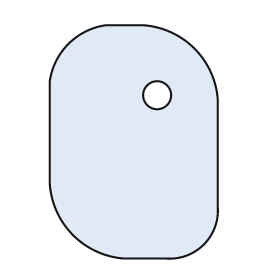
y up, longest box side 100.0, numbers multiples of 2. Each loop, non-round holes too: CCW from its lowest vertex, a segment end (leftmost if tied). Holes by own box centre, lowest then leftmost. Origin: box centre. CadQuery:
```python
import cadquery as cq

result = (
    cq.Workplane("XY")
    .moveTo(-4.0, -50.0)
    .lineTo(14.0, -50.0)
    .threePointArc((30.0, -44.0), (36.0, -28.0))
    .lineTo(36.0, 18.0)
    .threePointArc((26.0, 40.0), (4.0, 50.0))
    .lineTo(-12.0, 50.0)
    .threePointArc((-28.0, 42.0), (-36.0, 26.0))
    .lineTo(-36.0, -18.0)
    .threePointArc((-26.0, -40.0), (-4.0, -50.0))
    .close()
    .moveTo(10.0, 20.0)
    .circle(6.0)
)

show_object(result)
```